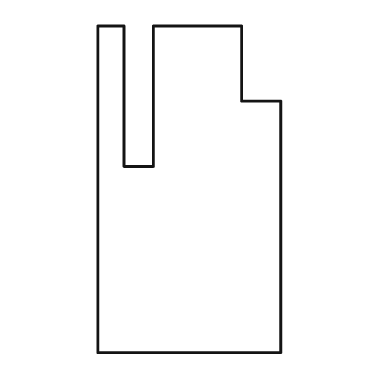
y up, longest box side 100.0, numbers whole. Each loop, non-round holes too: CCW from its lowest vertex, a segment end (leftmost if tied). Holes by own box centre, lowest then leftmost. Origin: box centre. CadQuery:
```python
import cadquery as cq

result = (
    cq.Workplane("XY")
    .moveTo(-28.0, -50.0)
    .lineTo(28.0, -50.0)
    .lineTo(28.0, 27.0)
    .lineTo(16.0, 27.0)
    .lineTo(16.0, 50.0)
    .lineTo(-11.0, 50.0)
    .lineTo(-11.0, 7.0)
    .lineTo(-20.0, 7.0)
    .lineTo(-20.0, 50.0)
    .lineTo(-28.0, 50.0)
    .close()
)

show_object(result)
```